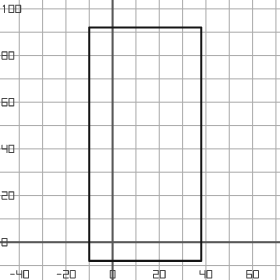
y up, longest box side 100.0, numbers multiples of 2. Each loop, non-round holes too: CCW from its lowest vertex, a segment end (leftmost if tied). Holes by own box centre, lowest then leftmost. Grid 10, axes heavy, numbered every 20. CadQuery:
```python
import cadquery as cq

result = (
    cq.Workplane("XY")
    .moveTo(-10.0, -8.0)
    .lineTo(38.0, -8.0)
    .lineTo(38.0, 92.0)
    .lineTo(-10.0, 92.0)
    .close()
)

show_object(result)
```